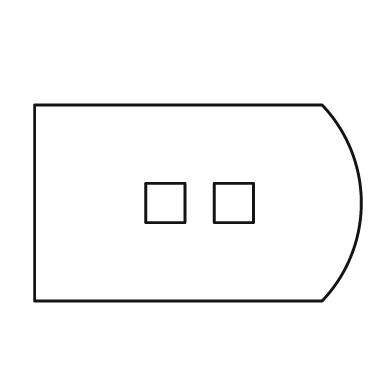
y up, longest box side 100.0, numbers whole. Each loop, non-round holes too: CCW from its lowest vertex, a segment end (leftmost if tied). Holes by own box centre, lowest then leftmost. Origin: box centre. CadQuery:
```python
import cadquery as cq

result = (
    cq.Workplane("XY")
    .moveTo(-50.0, -30.0)
    .lineTo(38.0, -30.0)
    .threePointArc((50.0, 0.0), (38.0, 30.0))
    .lineTo(-50.0, 30.0)
    .close()
    .moveTo(-16.0, -6.0)
    .lineTo(-4.0, -6.0)
    .lineTo(-4.0, 6.0)
    .lineTo(-16.0, 6.0)
    .close()
    .moveTo(5.0, -6.0)
    .lineTo(17.0, -6.0)
    .lineTo(17.0, 6.0)
    .lineTo(5.0, 6.0)
    .close()
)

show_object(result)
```